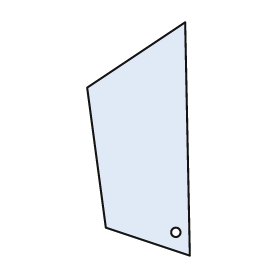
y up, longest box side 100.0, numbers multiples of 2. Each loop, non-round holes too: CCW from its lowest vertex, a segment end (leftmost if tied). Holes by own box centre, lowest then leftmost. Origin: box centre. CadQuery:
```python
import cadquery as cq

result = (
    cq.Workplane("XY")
    .moveTo(22.0, -50.0)
    .lineTo(20.0, 50.0)
    .lineTo(-22.0, 22.0)
    .lineTo(-14.0, -38.0)
    .close()
    .moveTo(16.0, -40.0)
    .circle(2.0)
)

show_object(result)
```